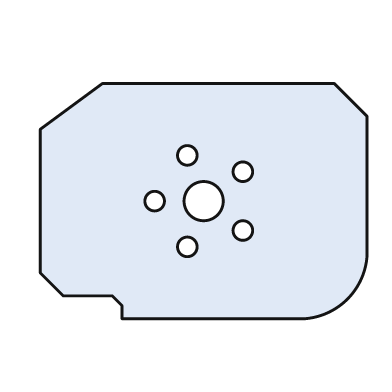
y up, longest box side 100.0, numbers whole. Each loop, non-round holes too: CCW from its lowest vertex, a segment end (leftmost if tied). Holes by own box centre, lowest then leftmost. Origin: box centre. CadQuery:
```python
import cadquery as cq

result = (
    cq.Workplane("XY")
    .moveTo(-25.0, -36.0)
    .lineTo(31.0, -36.0)
    .threePointArc((44.0, -30.0), (50.0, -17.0))
    .lineTo(50.0, 26.0)
    .lineTo(40.0, 36.0)
    .lineTo(-31.0, 36.0)
    .lineTo(-50.0, 22.0)
    .lineTo(-50.0, -22.0)
    .lineTo(-43.0, -29.0)
    .lineTo(-28.0, -29.0)
    .lineTo(-25.0, -32.0)
    .close()
    .moveTo(-5.0, -14.0)
    .circle(3.0)
    .moveTo(12.0, -9.0)
    .circle(3.0)
    .moveTo(-15.0, 0.0)
    .circle(3.0)
    .moveTo(0.0, 0.0)
    .circle(6.0)
    .moveTo(12.0, 9.0)
    .circle(3.0)
    .moveTo(-5.0, 14.0)
    .circle(3.0)
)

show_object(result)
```